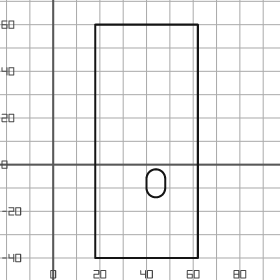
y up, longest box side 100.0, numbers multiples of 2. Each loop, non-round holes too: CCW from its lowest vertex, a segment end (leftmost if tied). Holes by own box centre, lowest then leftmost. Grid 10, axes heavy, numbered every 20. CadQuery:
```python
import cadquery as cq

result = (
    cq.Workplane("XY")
    .moveTo(18.0, -40.0)
    .lineTo(62.0, -40.0)
    .lineTo(62.0, 60.0)
    .lineTo(18.0, 60.0)
    .close()
    .moveTo(40.0, -10.0)
    .threePointArc((44.0, -14.0), (48.0, -10.0))
    .lineTo(48.0, -6.0)
    .threePointArc((44.0, -2.0), (40.0, -6.0))
    .close()
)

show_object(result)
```